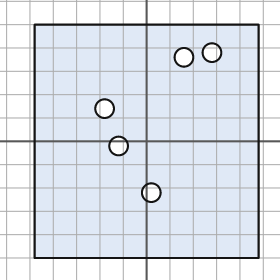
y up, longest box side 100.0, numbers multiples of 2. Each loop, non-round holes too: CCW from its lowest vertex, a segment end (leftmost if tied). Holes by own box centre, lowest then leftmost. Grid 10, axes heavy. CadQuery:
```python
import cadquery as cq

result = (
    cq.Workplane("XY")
    .moveTo(-48.0, -50.0)
    .lineTo(48.0, -50.0)
    .lineTo(48.0, 50.0)
    .lineTo(-48.0, 50.0)
    .close()
    .moveTo(2.0, -22.0)
    .circle(4.0)
    .moveTo(-12.0, -2.0)
    .circle(4.0)
    .moveTo(-18.0, 14.0)
    .circle(4.0)
    .moveTo(16.0, 36.0)
    .circle(4.0)
    .moveTo(28.0, 38.0)
    .circle(4.0)
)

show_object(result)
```